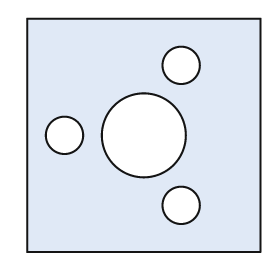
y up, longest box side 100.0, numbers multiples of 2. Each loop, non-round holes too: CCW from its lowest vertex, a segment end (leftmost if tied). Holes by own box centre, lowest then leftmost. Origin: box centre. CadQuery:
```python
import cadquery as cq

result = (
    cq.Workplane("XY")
    .moveTo(-50.0, -50.0)
    .lineTo(50.0, -50.0)
    .lineTo(50.0, 50.0)
    .lineTo(-50.0, 50.0)
    .close()
    .moveTo(16.0, -30.0)
    .circle(8.0)
    .moveTo(-34.0, 0.0)
    .circle(8.0)
    .moveTo(0.0, 0.0)
    .circle(18.0)
    .moveTo(16.0, 30.0)
    .circle(8.0)
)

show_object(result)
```